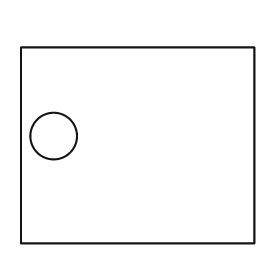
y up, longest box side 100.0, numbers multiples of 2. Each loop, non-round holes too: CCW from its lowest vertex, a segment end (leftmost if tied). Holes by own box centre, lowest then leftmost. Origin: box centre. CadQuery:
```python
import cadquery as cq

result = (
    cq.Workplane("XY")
    .moveTo(-50.0, -42.0)
    .lineTo(50.0, -42.0)
    .lineTo(50.0, 42.0)
    .lineTo(-50.0, 42.0)
    .close()
    .moveTo(-36.0, 4.0)
    .circle(10.0)
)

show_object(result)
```